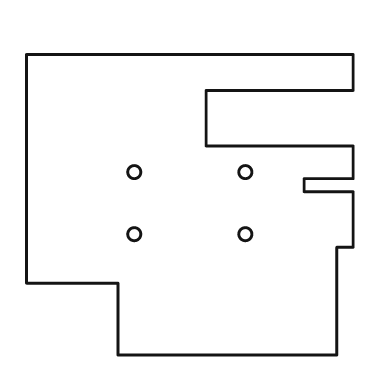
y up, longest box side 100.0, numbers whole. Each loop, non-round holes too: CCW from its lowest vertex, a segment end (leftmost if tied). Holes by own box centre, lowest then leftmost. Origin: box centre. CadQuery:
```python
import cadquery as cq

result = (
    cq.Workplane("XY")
    .moveTo(-22.0, -46.0)
    .lineTo(45.0, -46.0)
    .lineTo(45.0, -13.0)
    .lineTo(50.0, -13.0)
    .lineTo(50.0, 4.0)
    .lineTo(35.0, 4.0)
    .lineTo(35.0, 8.0)
    .lineTo(50.0, 8.0)
    .lineTo(50.0, 18.0)
    .lineTo(5.0, 18.0)
    .lineTo(5.0, 35.0)
    .lineTo(50.0, 35.0)
    .lineTo(50.0, 46.0)
    .lineTo(-50.0, 46.0)
    .lineTo(-50.0, -24.0)
    .lineTo(-22.0, -24.0)
    .close()
    .moveTo(-17.0, -9.0)
    .circle(2.0)
    .moveTo(17.0, -9.0)
    .circle(2.0)
    .moveTo(-17.0, 10.0)
    .circle(2.0)
    .moveTo(17.0, 10.0)
    .circle(2.0)
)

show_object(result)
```